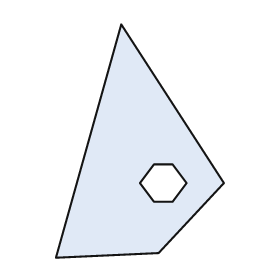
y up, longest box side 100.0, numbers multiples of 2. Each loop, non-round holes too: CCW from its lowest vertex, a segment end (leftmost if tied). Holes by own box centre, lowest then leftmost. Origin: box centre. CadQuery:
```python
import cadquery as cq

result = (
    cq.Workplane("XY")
    .moveTo(-36.0, -50.0)
    .lineTo(8.0, -48.0)
    .lineTo(36.0, -18.0)
    .lineTo(-8.0, 50.0)
    .close()
    .moveTo(6.0, -26.0)
    .lineTo(14.0, -26.0)
    .lineTo(20.0, -18.0)
    .lineTo(14.0, -10.0)
    .lineTo(6.0, -10.0)
    .lineTo(0.0, -18.0)
    .close()
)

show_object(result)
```